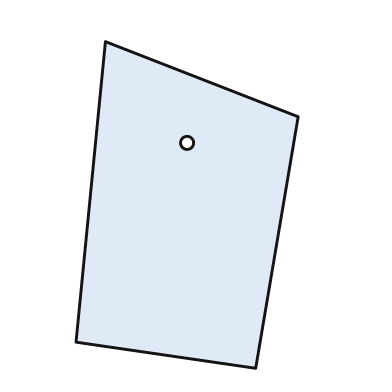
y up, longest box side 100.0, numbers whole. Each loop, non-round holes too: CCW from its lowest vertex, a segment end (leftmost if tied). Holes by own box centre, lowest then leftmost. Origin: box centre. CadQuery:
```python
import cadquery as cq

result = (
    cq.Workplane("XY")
    .moveTo(21.0, -50.0)
    .lineTo(34.0, 27.0)
    .lineTo(-25.0, 50.0)
    .lineTo(-34.0, -42.0)
    .close()
    .moveTo(0.0, 19.0)
    .circle(2.0)
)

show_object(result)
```